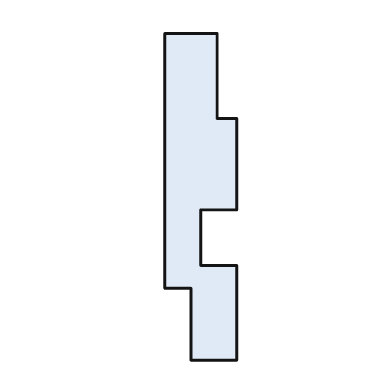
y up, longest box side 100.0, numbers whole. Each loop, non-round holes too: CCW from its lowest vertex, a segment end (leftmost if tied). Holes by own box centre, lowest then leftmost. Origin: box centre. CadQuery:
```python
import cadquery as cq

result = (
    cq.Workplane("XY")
    .moveTo(-3.0, -50.0)
    .lineTo(11.0, -50.0)
    .lineTo(11.0, -21.0)
    .lineTo(0.0, -21.0)
    .lineTo(0.0, -4.0)
    .lineTo(11.0, -4.0)
    .lineTo(11.0, 24.0)
    .lineTo(5.0, 24.0)
    .lineTo(5.0, 50.0)
    .lineTo(-11.0, 50.0)
    .lineTo(-11.0, -28.0)
    .lineTo(-3.0, -28.0)
    .close()
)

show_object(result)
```